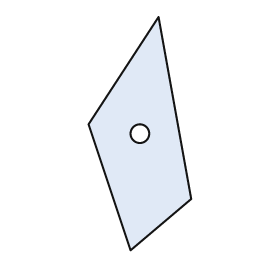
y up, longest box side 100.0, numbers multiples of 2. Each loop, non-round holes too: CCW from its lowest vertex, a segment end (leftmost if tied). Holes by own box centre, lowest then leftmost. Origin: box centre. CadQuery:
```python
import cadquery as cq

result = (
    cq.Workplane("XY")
    .moveTo(-4.0, -50.0)
    .lineTo(22.0, -28.0)
    .lineTo(8.0, 50.0)
    .lineTo(-22.0, 4.0)
    .close()
    .moveTo(0.0, 0.0)
    .circle(4.0)
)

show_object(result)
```